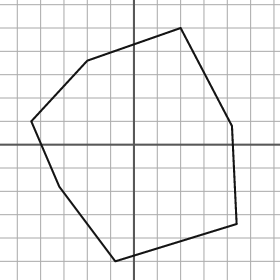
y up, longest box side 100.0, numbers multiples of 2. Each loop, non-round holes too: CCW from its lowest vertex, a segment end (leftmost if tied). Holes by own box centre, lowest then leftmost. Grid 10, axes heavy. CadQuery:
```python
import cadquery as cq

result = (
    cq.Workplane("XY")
    .moveTo(-8.0, -50.0)
    .lineTo(44.0, -34.0)
    .lineTo(42.0, 8.0)
    .lineTo(20.0, 50.0)
    .lineTo(-20.0, 36.0)
    .lineTo(-44.0, 10.0)
    .lineTo(-32.0, -18.0)
    .close()
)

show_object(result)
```